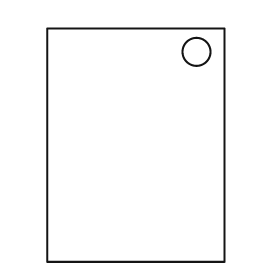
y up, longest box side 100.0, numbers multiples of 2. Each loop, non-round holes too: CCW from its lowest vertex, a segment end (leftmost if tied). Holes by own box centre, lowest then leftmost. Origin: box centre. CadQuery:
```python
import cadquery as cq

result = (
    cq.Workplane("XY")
    .moveTo(-38.0, -50.0)
    .lineTo(38.0, -50.0)
    .lineTo(38.0, 50.0)
    .lineTo(-38.0, 50.0)
    .close()
    .moveTo(26.0, 40.0)
    .circle(6.0)
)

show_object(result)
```